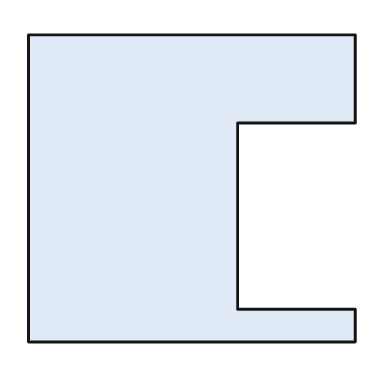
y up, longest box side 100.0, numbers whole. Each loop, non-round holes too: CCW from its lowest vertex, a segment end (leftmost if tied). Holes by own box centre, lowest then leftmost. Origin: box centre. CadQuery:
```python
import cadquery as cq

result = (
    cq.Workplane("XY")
    .moveTo(-50.0, -47.0)
    .lineTo(50.0, -47.0)
    .lineTo(50.0, -37.0)
    .lineTo(14.0, -37.0)
    .lineTo(14.0, 20.0)
    .lineTo(50.0, 20.0)
    .lineTo(50.0, 47.0)
    .lineTo(-50.0, 47.0)
    .close()
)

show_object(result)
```